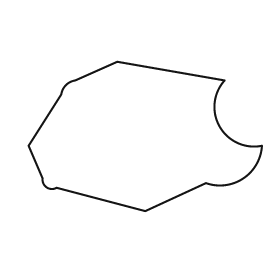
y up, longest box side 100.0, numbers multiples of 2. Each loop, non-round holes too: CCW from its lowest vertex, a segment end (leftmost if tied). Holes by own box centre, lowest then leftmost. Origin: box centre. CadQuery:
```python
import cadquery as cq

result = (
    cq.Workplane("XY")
    .moveTo(0.0, -32.0)
    .lineTo(26.0, -20.0)
    .threePointArc((42.0, -18.0), (50.0, -4.0))
    .threePointArc((32.0, 4.0), (34.0, 24.0))
    .lineTo(-12.0, 32.0)
    .lineTo(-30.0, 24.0)
    .threePointArc((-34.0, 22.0), (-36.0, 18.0))
    .lineTo(-50.0, -4.0)
    .lineTo(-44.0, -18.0)
    .threePointArc((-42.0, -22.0), (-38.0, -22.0))
    .close()
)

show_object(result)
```